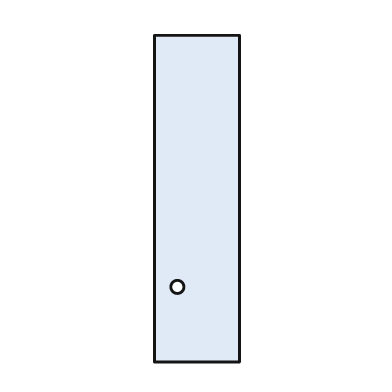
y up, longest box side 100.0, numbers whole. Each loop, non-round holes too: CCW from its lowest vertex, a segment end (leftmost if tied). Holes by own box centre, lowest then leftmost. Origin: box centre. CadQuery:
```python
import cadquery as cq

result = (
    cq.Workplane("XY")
    .moveTo(-13.0, -50.0)
    .lineTo(13.0, -50.0)
    .lineTo(13.0, 50.0)
    .lineTo(-13.0, 50.0)
    .close()
    .moveTo(-6.0, -27.0)
    .circle(2.0)
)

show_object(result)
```